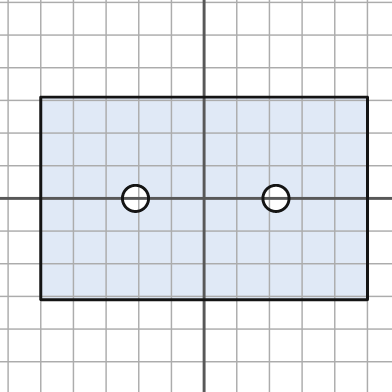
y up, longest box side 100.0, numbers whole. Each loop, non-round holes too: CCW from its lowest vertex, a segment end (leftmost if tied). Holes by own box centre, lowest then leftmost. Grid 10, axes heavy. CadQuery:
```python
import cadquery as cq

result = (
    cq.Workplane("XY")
    .moveTo(-50.0, -31.0)
    .lineTo(50.0, -31.0)
    .lineTo(50.0, 31.0)
    .lineTo(-50.0, 31.0)
    .close()
    .moveTo(-21.0, 0.0)
    .circle(4.0)
    .moveTo(22.0, 0.0)
    .circle(4.0)
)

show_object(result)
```